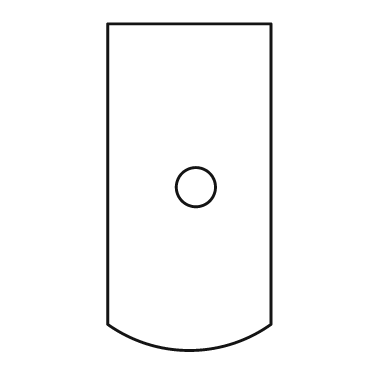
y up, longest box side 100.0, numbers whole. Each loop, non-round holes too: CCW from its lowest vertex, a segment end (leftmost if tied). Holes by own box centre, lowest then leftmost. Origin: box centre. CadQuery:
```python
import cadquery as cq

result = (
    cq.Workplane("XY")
    .moveTo(-25.0, -42.0)
    .threePointArc((0.0, -50.0), (25.0, -42.0))
    .lineTo(25.0, 50.0)
    .lineTo(-25.0, 50.0)
    .close()
    .moveTo(2.0, 0.0)
    .circle(6.0)
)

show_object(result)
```